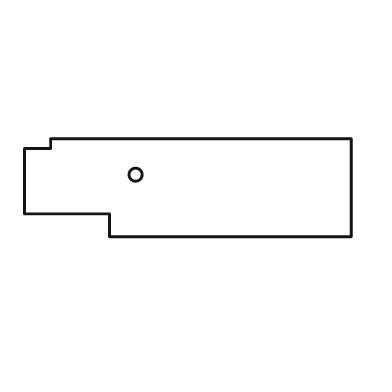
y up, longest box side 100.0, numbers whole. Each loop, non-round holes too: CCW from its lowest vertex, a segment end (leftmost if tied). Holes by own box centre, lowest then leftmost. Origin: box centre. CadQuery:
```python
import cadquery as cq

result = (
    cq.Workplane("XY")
    .moveTo(-24.0, -15.0)
    .lineTo(50.0, -15.0)
    .lineTo(50.0, 15.0)
    .lineTo(-42.0, 15.0)
    .lineTo(-42.0, 12.0)
    .lineTo(-50.0, 12.0)
    .lineTo(-50.0, -8.0)
    .lineTo(-24.0, -8.0)
    .close()
    .moveTo(-16.0, 4.0)
    .circle(2.0)
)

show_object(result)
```